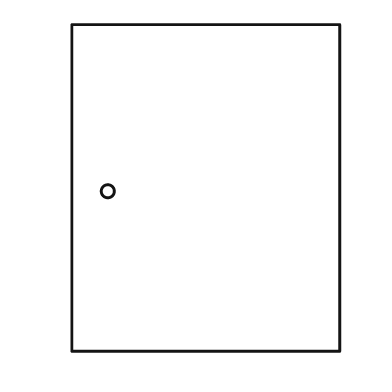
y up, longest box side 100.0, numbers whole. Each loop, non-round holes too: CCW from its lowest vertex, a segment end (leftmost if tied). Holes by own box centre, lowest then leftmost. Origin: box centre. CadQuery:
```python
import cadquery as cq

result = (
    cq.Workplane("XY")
    .moveTo(-41.0, -50.0)
    .lineTo(41.0, -50.0)
    .lineTo(41.0, 50.0)
    .lineTo(-41.0, 50.0)
    .close()
    .moveTo(-30.0, -1.0)
    .circle(2.0)
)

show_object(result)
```